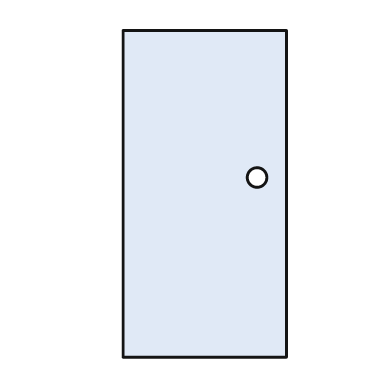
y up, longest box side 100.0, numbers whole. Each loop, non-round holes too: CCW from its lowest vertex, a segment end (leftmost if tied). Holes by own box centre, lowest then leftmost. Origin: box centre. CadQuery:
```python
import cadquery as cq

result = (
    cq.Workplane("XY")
    .moveTo(-25.0, -50.0)
    .lineTo(25.0, -50.0)
    .lineTo(25.0, 50.0)
    .lineTo(-25.0, 50.0)
    .close()
    .moveTo(16.0, 5.0)
    .circle(3.0)
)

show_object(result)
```